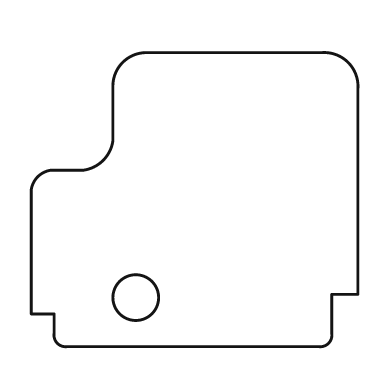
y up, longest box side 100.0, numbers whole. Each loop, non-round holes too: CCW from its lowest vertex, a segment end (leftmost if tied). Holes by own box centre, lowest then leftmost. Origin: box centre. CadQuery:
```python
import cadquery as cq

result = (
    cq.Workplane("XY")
    .moveTo(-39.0, -45.0)
    .lineTo(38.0, -45.0)
    .threePointArc((41.0, -44.0), (42.0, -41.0))
    .lineTo(42.0, -29.0)
    .lineTo(50.0, -29.0)
    .lineTo(50.0, 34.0)
    .threePointArc((47.0, 42.0), (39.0, 45.0))
    .lineTo(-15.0, 45.0)
    .threePointArc((-22.0, 42.0), (-25.0, 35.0))
    .lineTo(-25.0, 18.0)
    .threePointArc((-28.0, 12.0), (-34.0, 9.0))
    .lineTo(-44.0, 9.0)
    .threePointArc((-48.0, 7.0), (-50.0, 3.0))
    .lineTo(-50.0, -35.0)
    .lineTo(-43.0, -35.0)
    .lineTo(-43.0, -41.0)
    .threePointArc((-42.0, -44.0), (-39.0, -45.0))
    .close()
    .moveTo(-18.0, -30.0)
    .circle(7.0)
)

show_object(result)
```